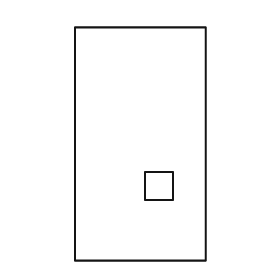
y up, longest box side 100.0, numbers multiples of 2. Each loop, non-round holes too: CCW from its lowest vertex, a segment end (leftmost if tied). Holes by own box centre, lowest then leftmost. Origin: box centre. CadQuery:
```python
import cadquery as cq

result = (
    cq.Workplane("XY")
    .moveTo(-28.0, -50.0)
    .lineTo(28.0, -50.0)
    .lineTo(28.0, 50.0)
    .lineTo(-28.0, 50.0)
    .close()
    .moveTo(2.0, -24.0)
    .lineTo(14.0, -24.0)
    .lineTo(14.0, -12.0)
    .lineTo(2.0, -12.0)
    .close()
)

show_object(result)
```